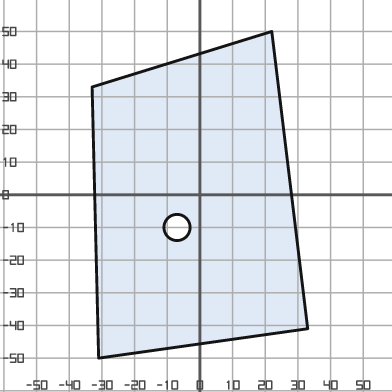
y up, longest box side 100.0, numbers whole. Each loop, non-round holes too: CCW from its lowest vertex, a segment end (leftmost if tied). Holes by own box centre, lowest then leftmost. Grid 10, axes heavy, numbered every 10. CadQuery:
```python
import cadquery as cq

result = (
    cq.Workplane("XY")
    .moveTo(-31.0, -50.0)
    .lineTo(33.0, -41.0)
    .lineTo(22.0, 50.0)
    .lineTo(-33.0, 33.0)
    .close()
    .moveTo(-7.0, -10.0)
    .circle(4.0)
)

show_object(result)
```